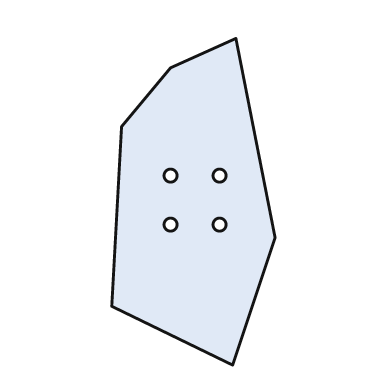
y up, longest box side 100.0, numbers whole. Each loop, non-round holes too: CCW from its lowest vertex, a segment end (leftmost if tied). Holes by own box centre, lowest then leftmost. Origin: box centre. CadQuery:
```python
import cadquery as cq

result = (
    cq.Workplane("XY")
    .moveTo(12.0, -50.0)
    .lineTo(25.0, -11.0)
    .lineTo(13.0, 50.0)
    .lineTo(-7.0, 41.0)
    .lineTo(-22.0, 23.0)
    .lineTo(-25.0, -32.0)
    .close()
    .moveTo(-7.0, -7.0)
    .circle(2.0)
    .moveTo(8.0, -7.0)
    .circle(2.0)
    .moveTo(-7.0, 8.0)
    .circle(2.0)
    .moveTo(8.0, 8.0)
    .circle(2.0)
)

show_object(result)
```